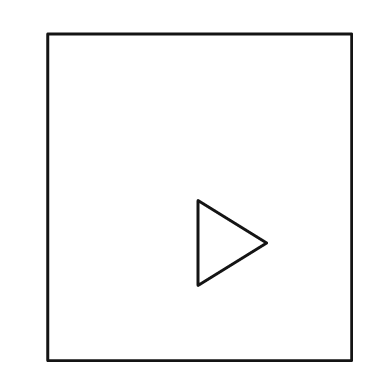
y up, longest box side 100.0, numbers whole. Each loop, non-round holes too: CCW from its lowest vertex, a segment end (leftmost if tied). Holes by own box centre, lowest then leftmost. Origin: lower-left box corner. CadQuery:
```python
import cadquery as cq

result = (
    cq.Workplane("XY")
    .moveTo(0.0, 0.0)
    .lineTo(93.0, 0.0)
    .lineTo(93.0, 100.0)
    .lineTo(0.0, 100.0)
    .close()
    .moveTo(46.0, 23.0)
    .lineTo(67.0, 36.0)
    .lineTo(46.0, 49.0)
    .close()
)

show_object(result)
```